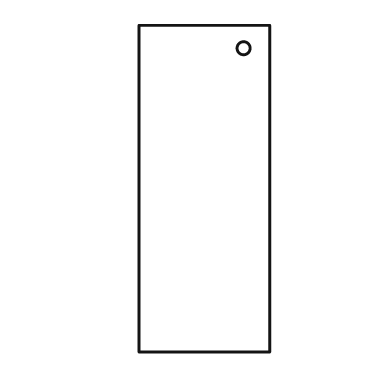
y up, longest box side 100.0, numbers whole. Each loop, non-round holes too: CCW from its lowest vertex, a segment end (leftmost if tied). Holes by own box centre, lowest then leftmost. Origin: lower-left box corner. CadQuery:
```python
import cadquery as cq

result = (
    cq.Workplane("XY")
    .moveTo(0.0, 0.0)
    .lineTo(40.0, 0.0)
    .lineTo(40.0, 100.0)
    .lineTo(0.0, 100.0)
    .close()
    .moveTo(32.0, 93.0)
    .circle(2.0)
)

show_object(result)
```